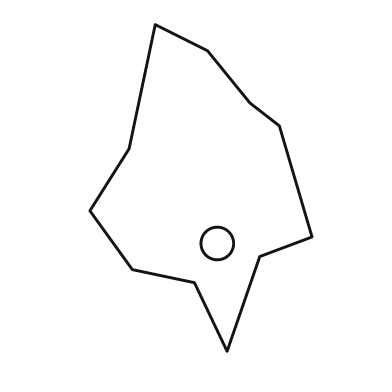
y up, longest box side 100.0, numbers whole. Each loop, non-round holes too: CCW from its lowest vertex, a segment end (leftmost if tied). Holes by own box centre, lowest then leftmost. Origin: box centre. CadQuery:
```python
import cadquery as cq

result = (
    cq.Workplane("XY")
    .moveTo(8.0, -50.0)
    .lineTo(18.0, -21.0)
    .lineTo(34.0, -15.0)
    .lineTo(24.0, 19.0)
    .lineTo(15.0, 26.0)
    .lineTo(2.0, 42.0)
    .lineTo(-14.0, 50.0)
    .lineTo(-22.0, 12.0)
    .lineTo(-34.0, -7.0)
    .lineTo(-21.0, -25.0)
    .lineTo(-2.0, -29.0)
    .close()
    .moveTo(5.0, -17.0)
    .circle(5.0)
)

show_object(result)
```